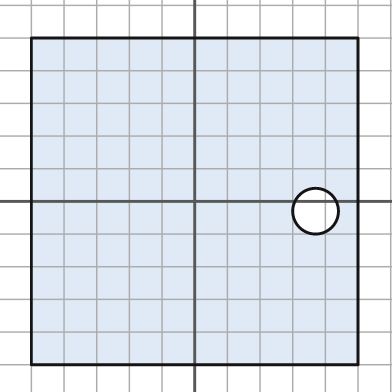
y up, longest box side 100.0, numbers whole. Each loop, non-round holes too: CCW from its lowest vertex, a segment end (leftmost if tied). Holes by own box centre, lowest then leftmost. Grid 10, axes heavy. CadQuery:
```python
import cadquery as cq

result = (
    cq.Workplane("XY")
    .moveTo(-50.0, -50.0)
    .lineTo(50.0, -50.0)
    .lineTo(50.0, 50.0)
    .lineTo(-50.0, 50.0)
    .close()
    .moveTo(37.0, -3.0)
    .circle(7.0)
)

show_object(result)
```